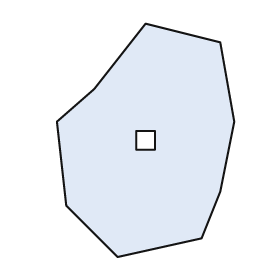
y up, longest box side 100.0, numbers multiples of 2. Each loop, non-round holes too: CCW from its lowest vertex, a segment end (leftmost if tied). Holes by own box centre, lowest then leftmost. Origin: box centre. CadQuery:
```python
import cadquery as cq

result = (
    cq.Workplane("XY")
    .moveTo(-12.0, -50.0)
    .lineTo(24.0, -42.0)
    .lineTo(32.0, -22.0)
    .lineTo(38.0, 8.0)
    .lineTo(32.0, 42.0)
    .lineTo(0.0, 50.0)
    .lineTo(-22.0, 22.0)
    .lineTo(-38.0, 8.0)
    .lineTo(-34.0, -28.0)
    .close()
    .moveTo(-4.0, -4.0)
    .lineTo(4.0, -4.0)
    .lineTo(4.0, 4.0)
    .lineTo(-4.0, 4.0)
    .close()
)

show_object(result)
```